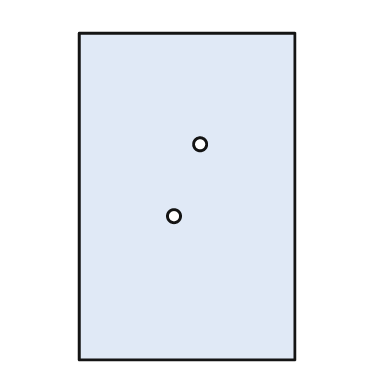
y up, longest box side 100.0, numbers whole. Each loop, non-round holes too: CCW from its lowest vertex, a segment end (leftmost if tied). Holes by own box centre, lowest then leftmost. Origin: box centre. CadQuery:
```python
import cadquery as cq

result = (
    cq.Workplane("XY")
    .moveTo(-33.0, -50.0)
    .lineTo(33.0, -50.0)
    .lineTo(33.0, 50.0)
    .lineTo(-33.0, 50.0)
    .close()
    .moveTo(-4.0, -6.0)
    .circle(2.0)
    .moveTo(4.0, 16.0)
    .circle(2.0)
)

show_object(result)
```